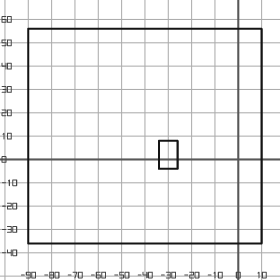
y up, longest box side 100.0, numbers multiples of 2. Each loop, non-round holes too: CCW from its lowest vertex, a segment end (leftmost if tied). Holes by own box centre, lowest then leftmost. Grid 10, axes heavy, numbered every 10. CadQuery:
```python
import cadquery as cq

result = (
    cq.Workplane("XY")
    .moveTo(-90.0, -36.0)
    .lineTo(10.0, -36.0)
    .lineTo(10.0, 56.0)
    .lineTo(-90.0, 56.0)
    .close()
    .moveTo(-34.0, -4.0)
    .lineTo(-26.0, -4.0)
    .lineTo(-26.0, 8.0)
    .lineTo(-34.0, 8.0)
    .close()
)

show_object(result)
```